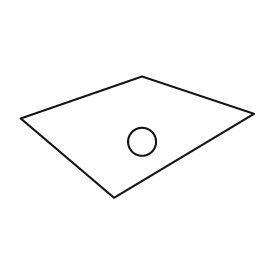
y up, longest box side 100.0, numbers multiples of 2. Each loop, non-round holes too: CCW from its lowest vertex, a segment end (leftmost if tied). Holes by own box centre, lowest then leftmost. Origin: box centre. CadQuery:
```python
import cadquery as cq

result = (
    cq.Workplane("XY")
    .moveTo(-10.0, -26.0)
    .lineTo(50.0, 10.0)
    .lineTo(2.0, 26.0)
    .lineTo(-50.0, 8.0)
    .close()
    .moveTo(2.0, -2.0)
    .circle(6.0)
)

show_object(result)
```